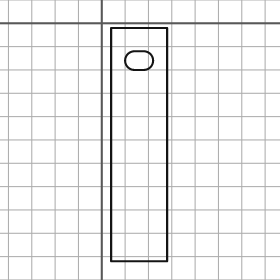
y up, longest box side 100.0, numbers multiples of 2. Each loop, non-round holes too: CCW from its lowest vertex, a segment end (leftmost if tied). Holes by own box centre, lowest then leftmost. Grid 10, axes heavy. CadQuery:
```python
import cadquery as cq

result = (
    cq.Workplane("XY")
    .moveTo(4.0, -102.0)
    .lineTo(28.0, -102.0)
    .lineTo(28.0, -2.0)
    .lineTo(4.0, -2.0)
    .close()
    .moveTo(14.0, -20.0)
    .lineTo(18.0, -20.0)
    .threePointArc((22.0, -16.0), (18.0, -12.0))
    .lineTo(14.0, -12.0)
    .threePointArc((10.0, -16.0), (14.0, -20.0))
    .close()
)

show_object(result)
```